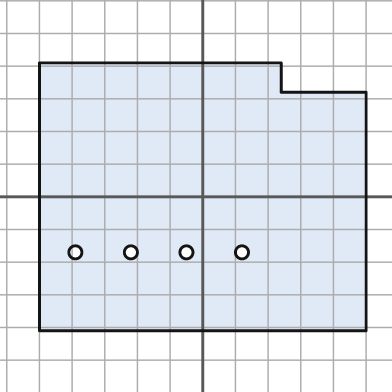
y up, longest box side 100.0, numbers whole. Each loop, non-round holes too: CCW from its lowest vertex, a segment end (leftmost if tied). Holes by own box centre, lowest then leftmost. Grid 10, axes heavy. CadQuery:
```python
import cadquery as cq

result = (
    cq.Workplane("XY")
    .moveTo(-50.0, -41.0)
    .lineTo(50.0, -41.0)
    .lineTo(50.0, 32.0)
    .lineTo(24.0, 32.0)
    .lineTo(24.0, 41.0)
    .lineTo(-50.0, 41.0)
    .close()
    .moveTo(-39.0, -17.0)
    .circle(2.0)
    .moveTo(-22.0, -17.0)
    .circle(2.0)
    .moveTo(-5.0, -17.0)
    .circle(2.0)
    .moveTo(12.0, -17.0)
    .circle(2.0)
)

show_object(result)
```